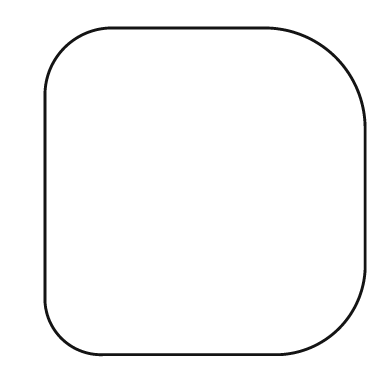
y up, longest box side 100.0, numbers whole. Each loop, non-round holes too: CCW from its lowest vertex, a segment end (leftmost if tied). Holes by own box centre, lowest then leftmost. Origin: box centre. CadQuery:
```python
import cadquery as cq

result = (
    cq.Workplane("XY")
    .moveTo(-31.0, -50.0)
    .lineTo(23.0, -50.0)
    .threePointArc((41.0, -42.0), (49.0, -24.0))
    .lineTo(49.0, 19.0)
    .threePointArc((40.0, 41.0), (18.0, 50.0))
    .lineTo(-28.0, 50.0)
    .threePointArc((-43.0, 44.0), (-49.0, 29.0))
    .lineTo(-49.0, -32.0)
    .threePointArc((-44.0, -45.0), (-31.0, -50.0))
    .close()
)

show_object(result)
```